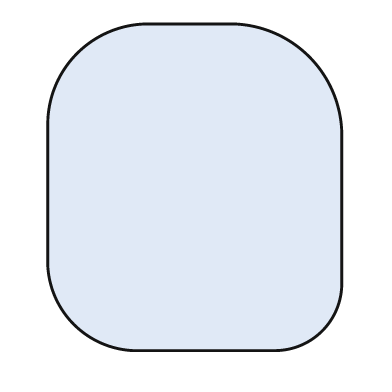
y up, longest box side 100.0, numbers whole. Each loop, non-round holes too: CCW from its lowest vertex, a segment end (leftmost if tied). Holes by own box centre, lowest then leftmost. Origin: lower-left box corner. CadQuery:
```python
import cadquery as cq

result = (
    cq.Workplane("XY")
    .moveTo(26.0, 0.0)
    .lineTo(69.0, 0.0)
    .threePointArc((84.0, 6.0), (90.0, 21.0))
    .lineTo(90.0, 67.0)
    .threePointArc((80.0, 90.0), (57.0, 100.0))
    .lineTo(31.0, 100.0)
    .threePointArc((9.0, 91.0), (0.0, 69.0))
    .lineTo(0.0, 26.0)
    .threePointArc((8.0, 8.0), (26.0, 0.0))
    .close()
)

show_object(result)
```